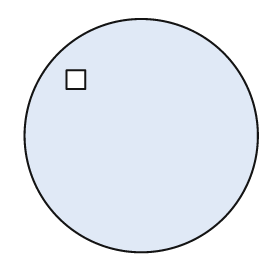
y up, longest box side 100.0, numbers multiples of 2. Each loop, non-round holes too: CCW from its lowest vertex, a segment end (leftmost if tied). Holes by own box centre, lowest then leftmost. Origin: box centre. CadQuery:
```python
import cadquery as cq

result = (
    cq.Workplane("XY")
    .moveTo(0.0, 0.0)
    .circle(50.0)
    .moveTo(-32.0, 20.0)
    .lineTo(-24.0, 20.0)
    .lineTo(-24.0, 28.0)
    .lineTo(-32.0, 28.0)
    .close()
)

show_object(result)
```